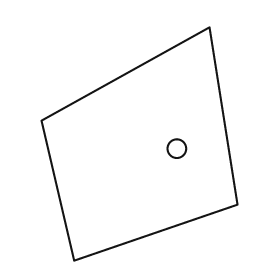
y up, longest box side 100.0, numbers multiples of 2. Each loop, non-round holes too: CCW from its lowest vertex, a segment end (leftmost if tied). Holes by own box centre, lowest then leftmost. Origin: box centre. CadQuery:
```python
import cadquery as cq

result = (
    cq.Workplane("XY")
    .moveTo(-28.0, -50.0)
    .lineTo(42.0, -26.0)
    .lineTo(30.0, 50.0)
    .lineTo(-42.0, 10.0)
    .close()
    .moveTo(16.0, -2.0)
    .circle(4.0)
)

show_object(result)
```